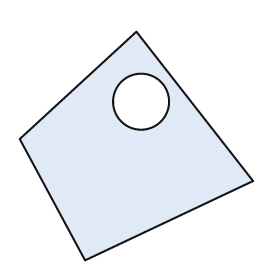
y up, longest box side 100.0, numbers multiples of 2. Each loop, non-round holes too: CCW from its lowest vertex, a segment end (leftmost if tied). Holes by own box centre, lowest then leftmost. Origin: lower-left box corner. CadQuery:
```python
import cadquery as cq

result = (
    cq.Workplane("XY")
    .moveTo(28.0, 0.0)
    .lineTo(100.0, 34.0)
    .lineTo(50.0, 98.0)
    .lineTo(0.0, 52.0)
    .close()
    .moveTo(52.0, 68.0)
    .circle(12.0)
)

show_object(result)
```